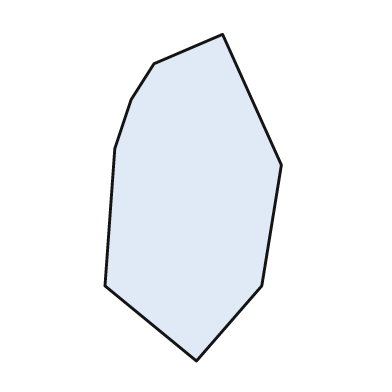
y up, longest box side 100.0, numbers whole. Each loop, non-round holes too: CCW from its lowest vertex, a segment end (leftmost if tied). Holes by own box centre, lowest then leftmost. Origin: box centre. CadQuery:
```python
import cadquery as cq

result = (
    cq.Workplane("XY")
    .moveTo(1.0, -50.0)
    .lineTo(21.0, -27.0)
    .lineTo(27.0, 10.0)
    .lineTo(9.0, 50.0)
    .lineTo(-12.0, 41.0)
    .lineTo(-19.0, 30.0)
    .lineTo(-24.0, 15.0)
    .lineTo(-27.0, -27.0)
    .close()
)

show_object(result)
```